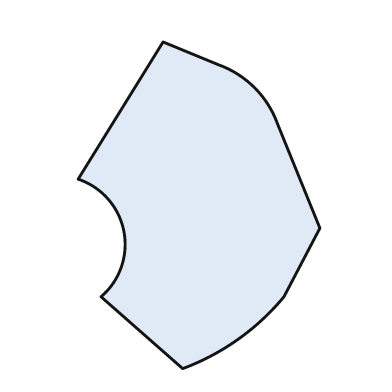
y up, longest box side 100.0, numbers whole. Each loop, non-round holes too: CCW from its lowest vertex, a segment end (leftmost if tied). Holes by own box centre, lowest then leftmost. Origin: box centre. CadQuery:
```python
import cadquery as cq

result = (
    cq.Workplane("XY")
    .moveTo(-5.0, -50.0)
    .threePointArc((12.0, -41.0), (26.0, -28.0))
    .lineTo(37.0, -7.0)
    .lineTo(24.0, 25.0)
    .threePointArc((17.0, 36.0), (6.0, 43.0))
    .lineTo(-11.0, 50.0)
    .lineTo(-37.0, 8.0)
    .threePointArc((-23.0, -8.0), (-30.0, -28.0))
    .close()
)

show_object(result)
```